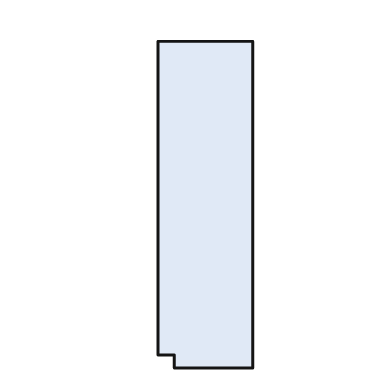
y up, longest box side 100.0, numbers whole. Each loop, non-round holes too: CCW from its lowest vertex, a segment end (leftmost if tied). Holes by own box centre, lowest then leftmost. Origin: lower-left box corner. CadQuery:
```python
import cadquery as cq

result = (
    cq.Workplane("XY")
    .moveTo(5.0, 0.0)
    .lineTo(29.0, 0.0)
    .lineTo(29.0, 100.0)
    .lineTo(0.0, 100.0)
    .lineTo(0.0, 4.0)
    .lineTo(5.0, 4.0)
    .close()
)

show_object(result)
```